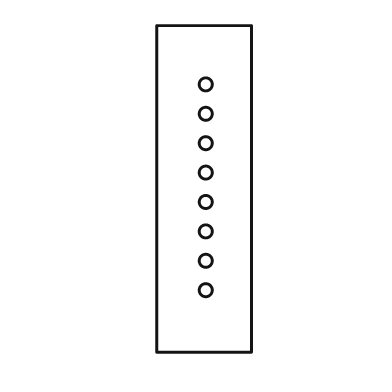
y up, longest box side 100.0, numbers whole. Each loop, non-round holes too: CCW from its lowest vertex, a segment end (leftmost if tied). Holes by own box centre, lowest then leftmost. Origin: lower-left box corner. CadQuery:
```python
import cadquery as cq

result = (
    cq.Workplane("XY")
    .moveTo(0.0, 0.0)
    .lineTo(29.0, 0.0)
    .lineTo(29.0, 100.0)
    .lineTo(0.0, 100.0)
    .close()
    .moveTo(15.0, 19.0)
    .circle(2.0)
    .moveTo(15.0, 28.0)
    .circle(2.0)
    .moveTo(15.0, 37.0)
    .circle(2.0)
    .moveTo(15.0, 46.0)
    .circle(2.0)
    .moveTo(15.0, 55.0)
    .circle(2.0)
    .moveTo(15.0, 64.0)
    .circle(2.0)
    .moveTo(15.0, 73.0)
    .circle(2.0)
    .moveTo(15.0, 82.0)
    .circle(2.0)
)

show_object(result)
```